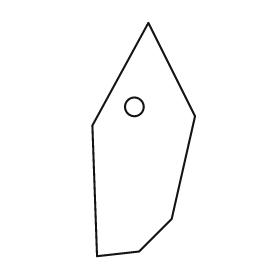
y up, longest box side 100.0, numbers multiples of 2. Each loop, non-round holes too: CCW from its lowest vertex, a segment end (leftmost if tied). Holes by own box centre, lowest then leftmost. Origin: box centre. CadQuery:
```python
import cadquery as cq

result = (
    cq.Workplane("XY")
    .moveTo(-20.0, -50.0)
    .lineTo(-2.0, -48.0)
    .lineTo(12.0, -34.0)
    .lineTo(22.0, 10.0)
    .lineTo(2.0, 50.0)
    .lineTo(-22.0, 6.0)
    .close()
    .moveTo(-4.0, 14.0)
    .circle(4.0)
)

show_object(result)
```